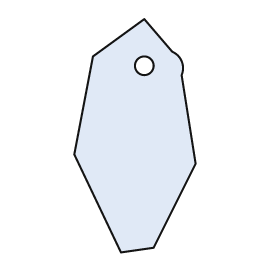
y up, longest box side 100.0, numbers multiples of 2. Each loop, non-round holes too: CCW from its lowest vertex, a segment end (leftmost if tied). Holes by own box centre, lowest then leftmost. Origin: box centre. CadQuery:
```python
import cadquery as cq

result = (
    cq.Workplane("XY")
    .moveTo(-6.0, -50.0)
    .lineTo(8.0, -48.0)
    .lineTo(26.0, -12.0)
    .lineTo(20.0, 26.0)
    .threePointArc((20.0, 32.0), (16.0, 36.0))
    .lineTo(4.0, 50.0)
    .lineTo(-18.0, 34.0)
    .lineTo(-26.0, -8.0)
    .close()
    .moveTo(4.0, 30.0)
    .circle(4.0)
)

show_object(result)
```